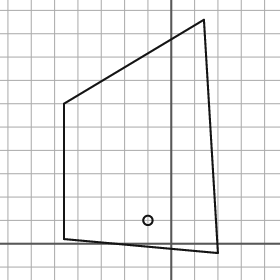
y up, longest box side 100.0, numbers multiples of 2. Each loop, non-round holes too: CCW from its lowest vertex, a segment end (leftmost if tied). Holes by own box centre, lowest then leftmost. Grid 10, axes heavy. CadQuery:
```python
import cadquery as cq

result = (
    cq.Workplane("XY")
    .moveTo(20.0, -4.0)
    .lineTo(14.0, 96.0)
    .lineTo(-46.0, 60.0)
    .lineTo(-46.0, 2.0)
    .close()
    .moveTo(-10.0, 10.0)
    .circle(2.0)
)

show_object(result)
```